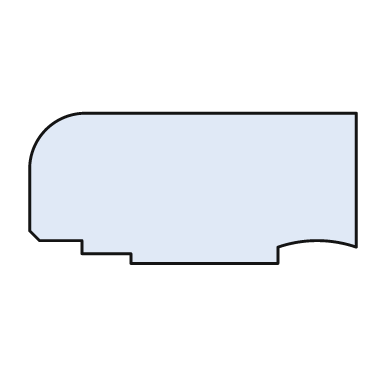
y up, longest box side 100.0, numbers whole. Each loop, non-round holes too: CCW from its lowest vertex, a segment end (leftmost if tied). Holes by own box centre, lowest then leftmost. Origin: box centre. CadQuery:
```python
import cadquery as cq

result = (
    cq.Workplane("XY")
    .moveTo(-19.0, -23.0)
    .lineTo(26.0, -23.0)
    .lineTo(26.0, -18.0)
    .threePointArc((38.0, -16.0), (50.0, -18.0))
    .lineTo(50.0, 23.0)
    .lineTo(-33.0, 23.0)
    .threePointArc((-45.0, 18.0), (-50.0, 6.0))
    .lineTo(-50.0, -13.0)
    .lineTo(-47.0, -16.0)
    .lineTo(-34.0, -16.0)
    .lineTo(-34.0, -20.0)
    .lineTo(-19.0, -20.0)
    .close()
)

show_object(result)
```